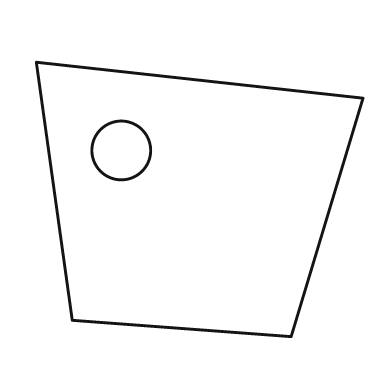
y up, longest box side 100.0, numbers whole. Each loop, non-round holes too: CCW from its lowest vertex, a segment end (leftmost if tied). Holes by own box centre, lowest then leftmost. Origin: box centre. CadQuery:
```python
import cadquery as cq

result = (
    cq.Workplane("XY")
    .moveTo(28.0, -42.0)
    .lineTo(50.0, 31.0)
    .lineTo(-50.0, 42.0)
    .lineTo(-39.0, -37.0)
    .close()
    .moveTo(-24.0, 15.0)
    .circle(9.0)
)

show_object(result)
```